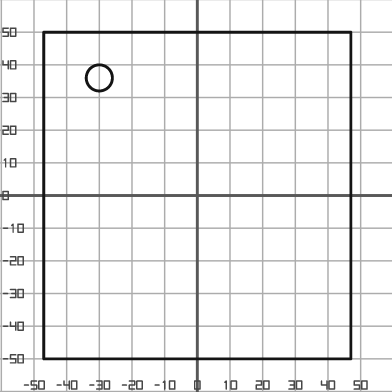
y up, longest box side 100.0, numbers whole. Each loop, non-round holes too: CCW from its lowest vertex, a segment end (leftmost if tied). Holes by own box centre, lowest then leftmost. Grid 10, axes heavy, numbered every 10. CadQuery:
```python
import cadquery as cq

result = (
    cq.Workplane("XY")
    .moveTo(-47.0, -50.0)
    .lineTo(47.0, -50.0)
    .lineTo(47.0, 50.0)
    .lineTo(-47.0, 50.0)
    .close()
    .moveTo(-30.0, 36.0)
    .circle(4.0)
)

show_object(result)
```